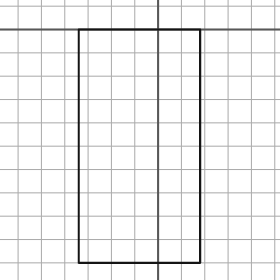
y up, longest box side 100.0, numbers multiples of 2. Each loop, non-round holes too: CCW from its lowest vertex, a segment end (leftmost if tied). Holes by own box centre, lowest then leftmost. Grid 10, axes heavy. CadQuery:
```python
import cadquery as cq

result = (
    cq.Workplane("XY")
    .moveTo(-34.0, -100.0)
    .lineTo(18.0, -100.0)
    .lineTo(18.0, 0.0)
    .lineTo(-34.0, 0.0)
    .close()
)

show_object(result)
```